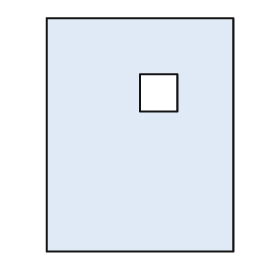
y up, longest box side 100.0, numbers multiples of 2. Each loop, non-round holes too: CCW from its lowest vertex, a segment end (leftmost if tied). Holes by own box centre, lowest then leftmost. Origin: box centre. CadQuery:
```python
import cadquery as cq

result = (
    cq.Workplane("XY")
    .moveTo(-40.0, -50.0)
    .lineTo(40.0, -50.0)
    .lineTo(40.0, 50.0)
    .lineTo(-40.0, 50.0)
    .close()
    .moveTo(0.0, 10.0)
    .lineTo(16.0, 10.0)
    .lineTo(16.0, 26.0)
    .lineTo(0.0, 26.0)
    .close()
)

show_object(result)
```